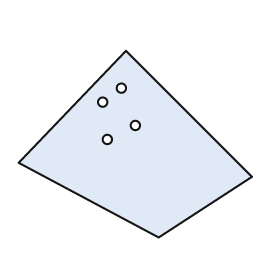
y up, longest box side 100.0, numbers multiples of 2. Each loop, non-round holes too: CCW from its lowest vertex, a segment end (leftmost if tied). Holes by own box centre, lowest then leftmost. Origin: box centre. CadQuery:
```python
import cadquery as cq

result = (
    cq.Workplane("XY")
    .moveTo(10.0, -40.0)
    .lineTo(50.0, -14.0)
    .lineTo(-4.0, 40.0)
    .lineTo(-50.0, -8.0)
    .close()
    .moveTo(-12.0, 2.0)
    .circle(2.0)
    .moveTo(0.0, 8.0)
    .circle(2.0)
    .moveTo(-14.0, 18.0)
    .circle(2.0)
    .moveTo(-6.0, 24.0)
    .circle(2.0)
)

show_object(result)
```